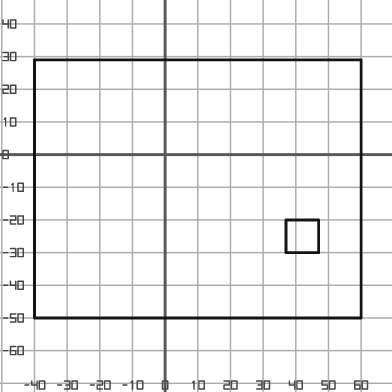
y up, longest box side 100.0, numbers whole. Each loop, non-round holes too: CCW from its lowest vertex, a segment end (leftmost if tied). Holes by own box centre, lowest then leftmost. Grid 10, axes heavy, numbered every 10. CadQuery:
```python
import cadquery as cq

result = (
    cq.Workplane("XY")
    .moveTo(-40.0, -50.0)
    .lineTo(60.0, -50.0)
    .lineTo(60.0, 29.0)
    .lineTo(-40.0, 29.0)
    .close()
    .moveTo(37.0, -30.0)
    .lineTo(47.0, -30.0)
    .lineTo(47.0, -20.0)
    .lineTo(37.0, -20.0)
    .close()
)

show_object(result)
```